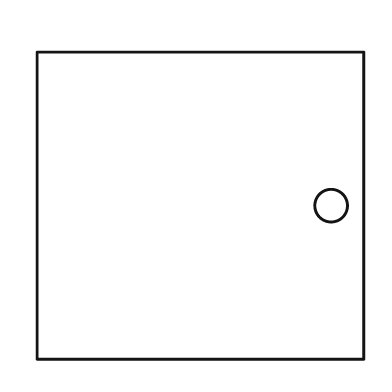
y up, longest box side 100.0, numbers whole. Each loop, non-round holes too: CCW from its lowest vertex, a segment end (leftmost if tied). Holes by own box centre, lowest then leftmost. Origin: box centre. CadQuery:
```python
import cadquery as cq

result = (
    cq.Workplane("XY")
    .moveTo(-50.0, -47.0)
    .lineTo(50.0, -47.0)
    .lineTo(50.0, 47.0)
    .lineTo(-50.0, 47.0)
    .close()
    .moveTo(40.0, 0.0)
    .circle(5.0)
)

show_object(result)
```